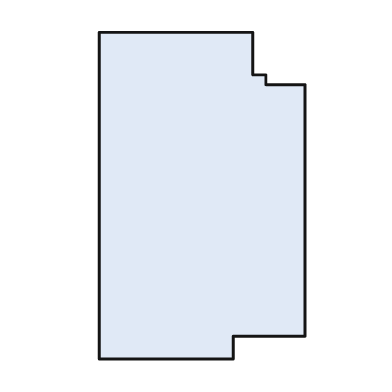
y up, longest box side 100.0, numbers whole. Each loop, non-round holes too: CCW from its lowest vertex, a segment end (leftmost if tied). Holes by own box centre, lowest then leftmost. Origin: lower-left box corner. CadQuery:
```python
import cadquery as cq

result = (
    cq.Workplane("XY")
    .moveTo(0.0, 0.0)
    .lineTo(41.0, 0.0)
    .lineTo(41.0, 7.0)
    .lineTo(63.0, 7.0)
    .lineTo(63.0, 84.0)
    .lineTo(51.0, 84.0)
    .lineTo(51.0, 87.0)
    .lineTo(47.0, 87.0)
    .lineTo(47.0, 100.0)
    .lineTo(0.0, 100.0)
    .close()
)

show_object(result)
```